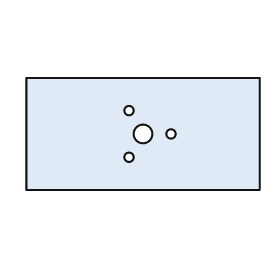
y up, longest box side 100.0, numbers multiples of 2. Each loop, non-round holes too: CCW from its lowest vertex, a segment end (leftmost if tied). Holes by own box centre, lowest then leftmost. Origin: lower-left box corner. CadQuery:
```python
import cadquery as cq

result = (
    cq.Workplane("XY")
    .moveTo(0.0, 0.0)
    .lineTo(100.0, 0.0)
    .lineTo(100.0, 48.0)
    .lineTo(0.0, 48.0)
    .close()
    .moveTo(44.0, 14.0)
    .circle(2.0)
    .moveTo(50.0, 24.0)
    .circle(4.0)
    .moveTo(62.0, 24.0)
    .circle(2.0)
    .moveTo(44.0, 34.0)
    .circle(2.0)
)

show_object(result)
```